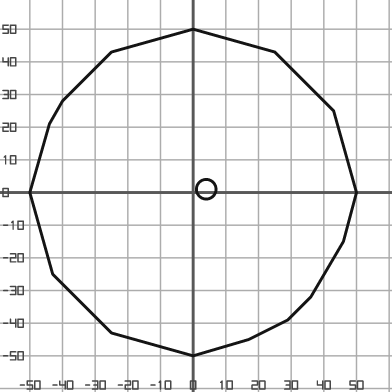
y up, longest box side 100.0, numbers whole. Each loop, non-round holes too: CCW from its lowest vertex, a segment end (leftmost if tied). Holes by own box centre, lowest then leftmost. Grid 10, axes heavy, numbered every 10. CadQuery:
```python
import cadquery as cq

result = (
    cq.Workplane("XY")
    .moveTo(0.0, -50.0)
    .lineTo(17.0, -45.0)
    .lineTo(29.0, -39.0)
    .lineTo(36.0, -32.0)
    .lineTo(46.0, -15.0)
    .lineTo(50.0, 0.0)
    .lineTo(43.0, 25.0)
    .lineTo(25.0, 43.0)
    .lineTo(0.0, 50.0)
    .lineTo(-25.0, 43.0)
    .lineTo(-40.0, 28.0)
    .lineTo(-44.0, 21.0)
    .lineTo(-50.0, 0.0)
    .lineTo(-43.0, -25.0)
    .lineTo(-25.0, -43.0)
    .close()
    .moveTo(4.0, 1.0)
    .circle(3.0)
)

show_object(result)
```